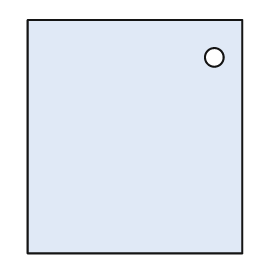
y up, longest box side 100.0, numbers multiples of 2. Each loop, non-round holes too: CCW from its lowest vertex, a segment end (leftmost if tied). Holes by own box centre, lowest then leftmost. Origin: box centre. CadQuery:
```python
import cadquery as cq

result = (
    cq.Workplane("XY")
    .moveTo(-46.0, -50.0)
    .lineTo(46.0, -50.0)
    .lineTo(46.0, 50.0)
    .lineTo(-46.0, 50.0)
    .close()
    .moveTo(34.0, 34.0)
    .circle(4.0)
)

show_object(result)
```